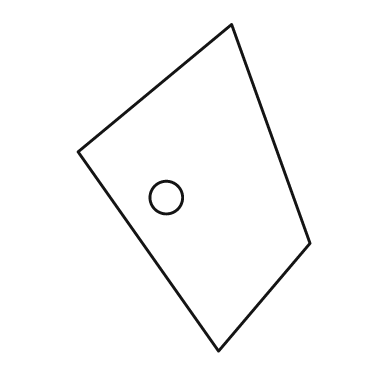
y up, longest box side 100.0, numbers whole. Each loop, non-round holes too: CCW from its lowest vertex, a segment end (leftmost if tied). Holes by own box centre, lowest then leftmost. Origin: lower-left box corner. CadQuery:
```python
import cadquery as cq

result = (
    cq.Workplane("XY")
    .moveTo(43.0, 0.0)
    .lineTo(71.0, 33.0)
    .lineTo(47.0, 100.0)
    .lineTo(0.0, 61.0)
    .close()
    .moveTo(27.0, 47.0)
    .circle(5.0)
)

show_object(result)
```